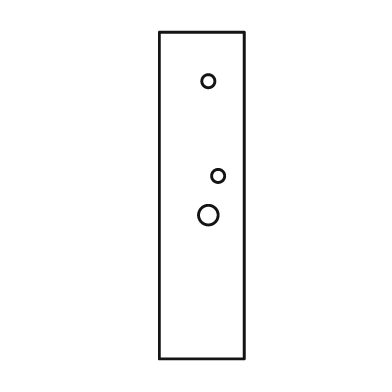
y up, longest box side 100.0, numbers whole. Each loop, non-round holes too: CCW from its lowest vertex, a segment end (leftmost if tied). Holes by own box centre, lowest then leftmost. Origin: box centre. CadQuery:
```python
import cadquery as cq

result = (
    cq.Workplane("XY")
    .moveTo(-13.0, -50.0)
    .lineTo(13.0, -50.0)
    .lineTo(13.0, 50.0)
    .lineTo(-13.0, 50.0)
    .close()
    .moveTo(2.0, -6.0)
    .circle(3.0)
    .moveTo(5.0, 6.0)
    .circle(2.0)
    .moveTo(2.0, 35.0)
    .circle(2.0)
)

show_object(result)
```